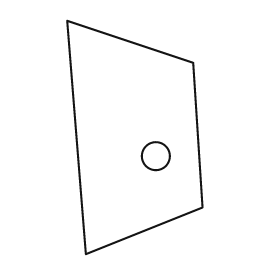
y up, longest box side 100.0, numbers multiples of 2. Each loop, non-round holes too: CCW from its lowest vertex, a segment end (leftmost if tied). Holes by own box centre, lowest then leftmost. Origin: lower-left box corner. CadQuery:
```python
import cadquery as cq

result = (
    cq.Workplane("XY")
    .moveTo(8.0, 0.0)
    .lineTo(58.0, 20.0)
    .lineTo(54.0, 82.0)
    .lineTo(0.0, 100.0)
    .close()
    .moveTo(38.0, 42.0)
    .circle(6.0)
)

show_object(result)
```